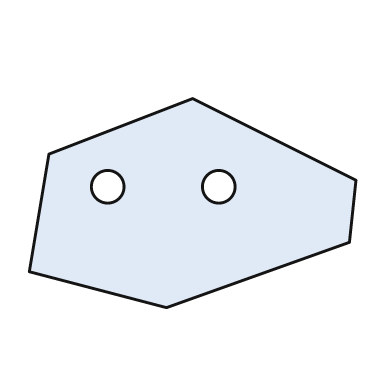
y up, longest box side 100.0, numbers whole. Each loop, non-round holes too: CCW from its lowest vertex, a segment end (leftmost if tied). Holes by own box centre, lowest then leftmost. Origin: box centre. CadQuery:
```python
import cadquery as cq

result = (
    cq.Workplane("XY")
    .moveTo(-8.0, -32.0)
    .lineTo(48.0, -12.0)
    .lineTo(50.0, 7.0)
    .lineTo(0.0, 32.0)
    .lineTo(-44.0, 15.0)
    .lineTo(-50.0, -21.0)
    .close()
    .moveTo(-26.0, 5.0)
    .circle(5.0)
    .moveTo(8.0, 5.0)
    .circle(5.0)
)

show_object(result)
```